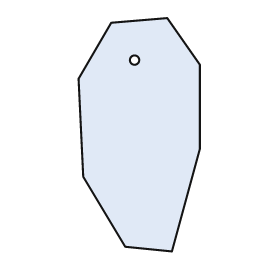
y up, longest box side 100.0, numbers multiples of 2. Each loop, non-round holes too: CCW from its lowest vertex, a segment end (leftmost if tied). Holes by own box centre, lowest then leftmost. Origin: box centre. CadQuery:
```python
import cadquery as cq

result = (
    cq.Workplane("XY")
    .moveTo(14.0, -50.0)
    .lineTo(26.0, -6.0)
    .lineTo(26.0, 30.0)
    .lineTo(12.0, 50.0)
    .lineTo(-12.0, 48.0)
    .lineTo(-26.0, 24.0)
    .lineTo(-24.0, -18.0)
    .lineTo(-6.0, -48.0)
    .close()
    .moveTo(-2.0, 32.0)
    .circle(2.0)
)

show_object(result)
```